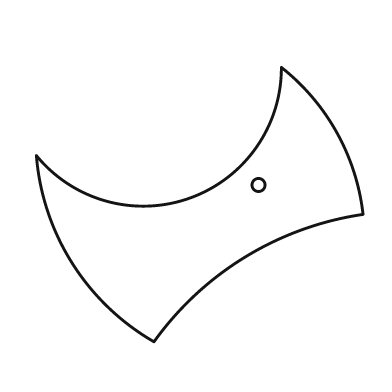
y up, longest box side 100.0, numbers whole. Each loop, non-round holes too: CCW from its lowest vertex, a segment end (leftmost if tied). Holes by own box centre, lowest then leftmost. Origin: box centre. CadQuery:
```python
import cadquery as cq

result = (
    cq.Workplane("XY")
    .moveTo(-14.0, -42.0)
    .threePointArc((14.0, -16.0), (50.0, -3.0))
    .threePointArc((42.0, 22.0), (25.0, 42.0))
    .threePointArc((-3.0, 2.0), (-50.0, 15.0))
    .threePointArc((-39.0, -18.0), (-14.0, -42.0))
    .close()
    .moveTo(18.0, 6.0)
    .circle(2.0)
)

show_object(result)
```